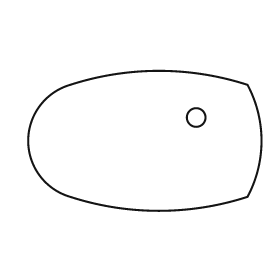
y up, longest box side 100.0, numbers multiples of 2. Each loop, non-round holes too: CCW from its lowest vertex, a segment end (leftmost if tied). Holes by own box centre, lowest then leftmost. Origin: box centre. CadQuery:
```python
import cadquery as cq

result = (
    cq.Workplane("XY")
    .moveTo(-32.0, -24.0)
    .threePointArc((6.0, -30.0), (44.0, -24.0))
    .threePointArc((50.0, 0.0), (44.0, 24.0))
    .threePointArc((6.0, 30.0), (-32.0, 24.0))
    .threePointArc((-50.0, 0.0), (-32.0, -24.0))
    .close()
    .moveTo(22.0, 10.0)
    .circle(4.0)
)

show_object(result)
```